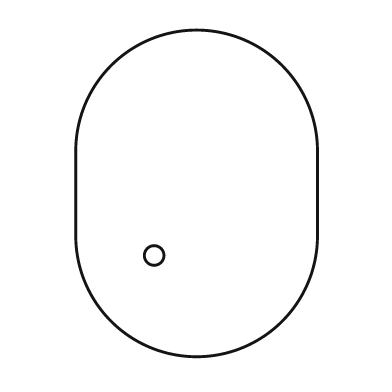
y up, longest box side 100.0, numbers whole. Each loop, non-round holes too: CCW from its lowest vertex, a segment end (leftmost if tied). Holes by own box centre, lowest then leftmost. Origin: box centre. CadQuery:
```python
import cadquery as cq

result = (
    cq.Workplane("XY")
    .moveTo(-37.0, -13.0)
    .threePointArc((0.0, -50.0), (37.0, -13.0))
    .lineTo(37.0, 13.0)
    .threePointArc((0.0, 50.0), (-37.0, 13.0))
    .close()
    .moveTo(-13.0, -19.0)
    .circle(3.0)
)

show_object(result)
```